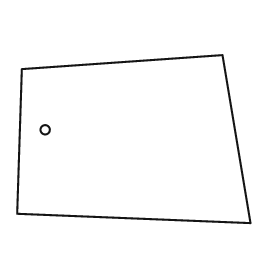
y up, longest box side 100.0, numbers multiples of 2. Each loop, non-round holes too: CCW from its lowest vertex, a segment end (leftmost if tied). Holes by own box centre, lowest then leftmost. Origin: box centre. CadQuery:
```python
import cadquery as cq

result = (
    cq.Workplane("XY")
    .moveTo(50.0, -36.0)
    .lineTo(38.0, 36.0)
    .lineTo(-48.0, 30.0)
    .lineTo(-50.0, -32.0)
    .close()
    .moveTo(-38.0, 4.0)
    .circle(2.0)
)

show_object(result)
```